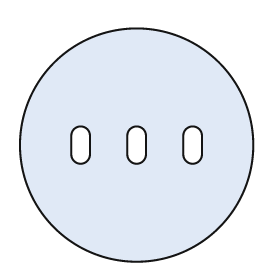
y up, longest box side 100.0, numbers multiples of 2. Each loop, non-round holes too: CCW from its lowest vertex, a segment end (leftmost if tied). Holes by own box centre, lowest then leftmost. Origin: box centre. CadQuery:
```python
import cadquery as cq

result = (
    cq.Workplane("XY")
    .moveTo(0.0, 0.0)
    .circle(50.0)
    .moveTo(-28.0, -4.0)
    .threePointArc((-24.0, -8.0), (-20.0, -4.0))
    .lineTo(-20.0, 4.0)
    .threePointArc((-24.0, 8.0), (-28.0, 4.0))
    .close()
    .moveTo(-4.0, -4.0)
    .threePointArc((0.0, -8.0), (4.0, -4.0))
    .lineTo(4.0, 4.0)
    .threePointArc((0.0, 8.0), (-4.0, 4.0))
    .close()
    .moveTo(20.0, -4.0)
    .threePointArc((24.0, -8.0), (28.0, -4.0))
    .lineTo(28.0, 4.0)
    .threePointArc((24.0, 8.0), (20.0, 4.0))
    .close()
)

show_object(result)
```